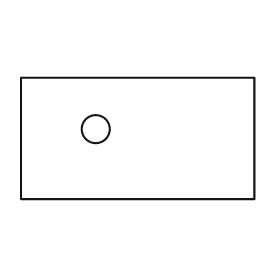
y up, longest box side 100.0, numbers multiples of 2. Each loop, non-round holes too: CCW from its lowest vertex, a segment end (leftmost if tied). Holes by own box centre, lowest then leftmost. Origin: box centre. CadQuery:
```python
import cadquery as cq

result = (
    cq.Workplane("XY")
    .moveTo(-50.0, -26.0)
    .lineTo(50.0, -26.0)
    .lineTo(50.0, 26.0)
    .lineTo(-50.0, 26.0)
    .close()
    .moveTo(-18.0, 4.0)
    .circle(6.0)
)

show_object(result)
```